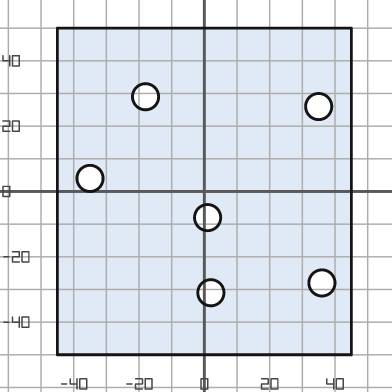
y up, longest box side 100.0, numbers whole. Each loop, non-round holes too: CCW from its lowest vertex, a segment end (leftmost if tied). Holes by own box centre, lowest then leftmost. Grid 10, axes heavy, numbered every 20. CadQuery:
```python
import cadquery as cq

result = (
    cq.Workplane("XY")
    .moveTo(-45.0, -50.0)
    .lineTo(45.0, -50.0)
    .lineTo(45.0, 50.0)
    .lineTo(-45.0, 50.0)
    .close()
    .moveTo(2.0, -31.0)
    .circle(4.0)
    .moveTo(36.0, -28.0)
    .circle(4.0)
    .moveTo(1.0, -8.0)
    .circle(4.0)
    .moveTo(-35.0, 4.0)
    .circle(4.0)
    .moveTo(35.0, 26.0)
    .circle(4.0)
    .moveTo(-18.0, 29.0)
    .circle(4.0)
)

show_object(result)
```